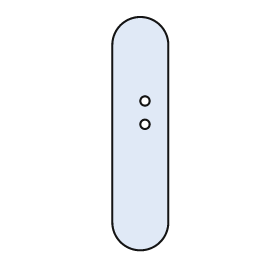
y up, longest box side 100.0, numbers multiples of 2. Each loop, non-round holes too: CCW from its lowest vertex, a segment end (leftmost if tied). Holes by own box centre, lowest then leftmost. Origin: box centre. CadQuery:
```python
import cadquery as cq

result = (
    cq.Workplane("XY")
    .moveTo(-12.0, -38.0)
    .threePointArc((0.0, -50.0), (12.0, -38.0))
    .lineTo(12.0, 38.0)
    .threePointArc((0.0, 50.0), (-12.0, 38.0))
    .close()
    .moveTo(2.0, 4.0)
    .circle(2.0)
    .moveTo(2.0, 14.0)
    .circle(2.0)
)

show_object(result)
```